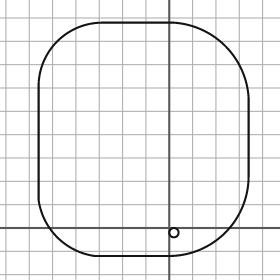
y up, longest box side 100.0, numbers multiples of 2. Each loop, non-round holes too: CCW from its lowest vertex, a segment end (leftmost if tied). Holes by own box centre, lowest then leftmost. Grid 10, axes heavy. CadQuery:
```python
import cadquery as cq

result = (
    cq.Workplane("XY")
    .moveTo(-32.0, -12.0)
    .lineTo(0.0, -12.0)
    .threePointArc((24.0, -2.0), (34.0, 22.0))
    .lineTo(34.0, 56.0)
    .threePointArc((24.0, 78.0), (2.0, 88.0))
    .lineTo(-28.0, 88.0)
    .threePointArc((-48.0, 80.0), (-56.0, 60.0))
    .lineTo(-56.0, 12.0)
    .threePointArc((-48.0, -4.0), (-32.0, -12.0))
    .close()
    .moveTo(2.0, -2.0)
    .circle(2.0)
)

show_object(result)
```